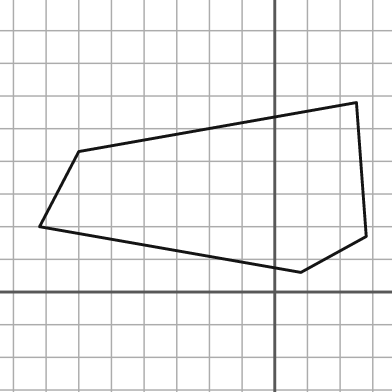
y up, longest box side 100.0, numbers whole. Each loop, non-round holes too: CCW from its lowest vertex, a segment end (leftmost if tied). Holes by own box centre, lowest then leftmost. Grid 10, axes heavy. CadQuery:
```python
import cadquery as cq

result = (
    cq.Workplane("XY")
    .moveTo(8.0, 6.0)
    .lineTo(28.0, 17.0)
    .lineTo(25.0, 58.0)
    .lineTo(-60.0, 43.0)
    .lineTo(-72.0, 20.0)
    .close()
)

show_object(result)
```